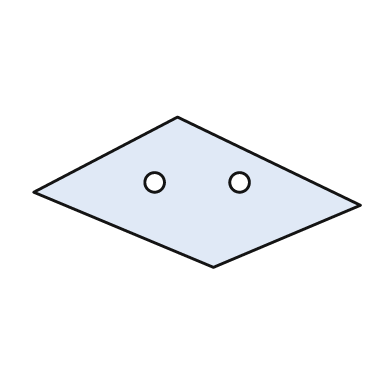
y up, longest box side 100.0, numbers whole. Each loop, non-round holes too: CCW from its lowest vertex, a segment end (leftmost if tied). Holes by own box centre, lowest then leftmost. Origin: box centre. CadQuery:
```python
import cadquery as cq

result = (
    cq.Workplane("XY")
    .moveTo(5.0, -23.0)
    .lineTo(50.0, -4.0)
    .lineTo(-6.0, 23.0)
    .lineTo(-50.0, 0.0)
    .close()
    .moveTo(-13.0, 3.0)
    .circle(3.0)
    .moveTo(13.0, 3.0)
    .circle(3.0)
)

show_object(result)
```